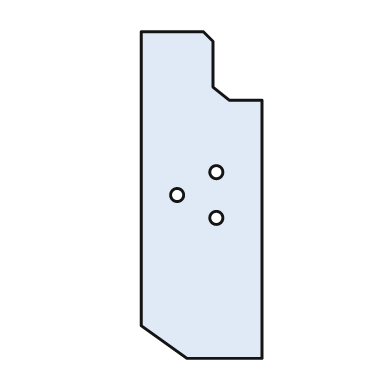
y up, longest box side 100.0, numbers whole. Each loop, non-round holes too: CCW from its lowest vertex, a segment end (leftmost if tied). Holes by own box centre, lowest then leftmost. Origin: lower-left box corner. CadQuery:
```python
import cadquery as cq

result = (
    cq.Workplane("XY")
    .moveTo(14.0, 0.0)
    .lineTo(37.0, 0.0)
    .lineTo(37.0, 79.0)
    .lineTo(27.0, 79.0)
    .lineTo(22.0, 83.0)
    .lineTo(22.0, 97.0)
    .lineTo(19.0, 100.0)
    .lineTo(0.0, 100.0)
    .lineTo(0.0, 10.0)
    .close()
    .moveTo(23.0, 43.0)
    .circle(2.0)
    .moveTo(11.0, 50.0)
    .circle(2.0)
    .moveTo(23.0, 57.0)
    .circle(2.0)
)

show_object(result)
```